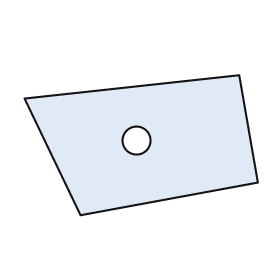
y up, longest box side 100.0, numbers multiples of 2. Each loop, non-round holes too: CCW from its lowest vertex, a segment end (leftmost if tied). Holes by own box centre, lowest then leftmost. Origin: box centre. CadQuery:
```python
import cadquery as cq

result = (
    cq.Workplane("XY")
    .moveTo(-26.0, -30.0)
    .lineTo(50.0, -16.0)
    .lineTo(42.0, 30.0)
    .lineTo(-50.0, 20.0)
    .close()
    .moveTo(-2.0, 2.0)
    .circle(6.0)
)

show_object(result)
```